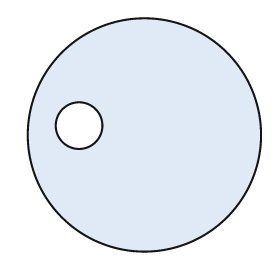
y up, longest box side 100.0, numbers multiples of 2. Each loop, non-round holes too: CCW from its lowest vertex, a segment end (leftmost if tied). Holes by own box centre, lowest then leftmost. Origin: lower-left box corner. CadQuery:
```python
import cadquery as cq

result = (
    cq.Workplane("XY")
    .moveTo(50.0, 50.0)
    .circle(50.0)
    .moveTo(22.0, 54.0)
    .circle(10.0)
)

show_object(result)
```